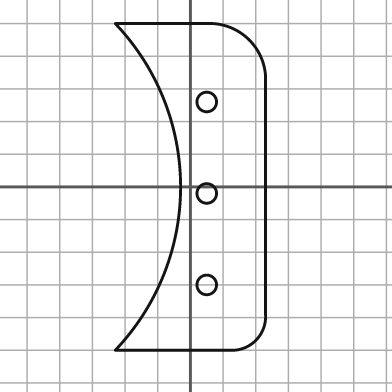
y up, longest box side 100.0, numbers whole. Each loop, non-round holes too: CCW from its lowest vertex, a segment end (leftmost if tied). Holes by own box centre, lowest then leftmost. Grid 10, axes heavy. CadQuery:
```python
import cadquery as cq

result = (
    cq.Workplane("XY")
    .moveTo(-23.0, -50.0)
    .lineTo(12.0, -50.0)
    .threePointArc((20.0, -47.0), (23.0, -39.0))
    .lineTo(23.0, 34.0)
    .threePointArc((18.0, 45.0), (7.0, 50.0))
    .lineTo(-23.0, 50.0)
    .threePointArc((-3.0, 0.0), (-23.0, -50.0))
    .close()
    .moveTo(5.0, -30.0)
    .circle(3.0)
    .moveTo(5.0, -2.0)
    .circle(3.0)
    .moveTo(5.0, 26.0)
    .circle(3.0)
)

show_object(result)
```